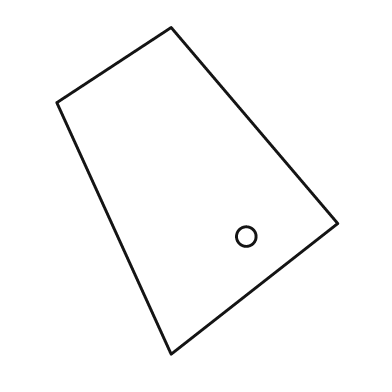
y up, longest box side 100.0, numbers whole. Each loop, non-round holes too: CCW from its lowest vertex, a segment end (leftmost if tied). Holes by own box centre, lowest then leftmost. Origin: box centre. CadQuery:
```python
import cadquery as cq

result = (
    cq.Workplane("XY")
    .moveTo(-8.0, -50.0)
    .lineTo(43.0, -10.0)
    .lineTo(-8.0, 50.0)
    .lineTo(-43.0, 27.0)
    .close()
    .moveTo(15.0, -14.0)
    .circle(3.0)
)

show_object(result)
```